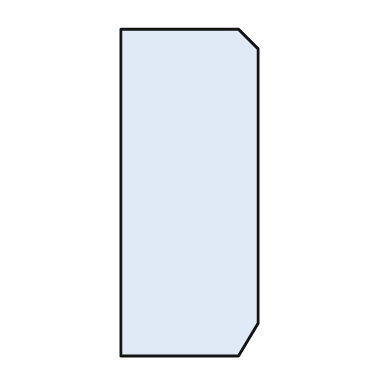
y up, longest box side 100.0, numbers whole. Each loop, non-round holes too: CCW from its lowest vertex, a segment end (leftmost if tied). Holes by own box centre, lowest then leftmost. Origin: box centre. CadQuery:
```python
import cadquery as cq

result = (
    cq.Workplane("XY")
    .moveTo(-21.0, -50.0)
    .lineTo(15.0, -50.0)
    .lineTo(21.0, -40.0)
    .lineTo(21.0, 44.0)
    .lineTo(15.0, 50.0)
    .lineTo(-21.0, 50.0)
    .close()
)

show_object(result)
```